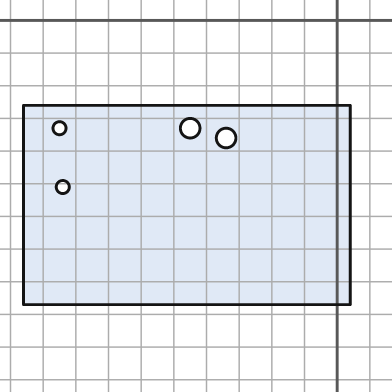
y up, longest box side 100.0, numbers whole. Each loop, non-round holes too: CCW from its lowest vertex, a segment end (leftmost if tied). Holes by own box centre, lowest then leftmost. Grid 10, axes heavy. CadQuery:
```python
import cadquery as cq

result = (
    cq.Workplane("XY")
    .moveTo(-96.0, -87.0)
    .lineTo(4.0, -87.0)
    .lineTo(4.0, -26.0)
    .lineTo(-96.0, -26.0)
    .close()
    .moveTo(-84.0, -51.0)
    .circle(2.0)
    .moveTo(-34.0, -36.0)
    .circle(3.0)
    .moveTo(-85.0, -33.0)
    .circle(2.0)
    .moveTo(-45.0, -33.0)
    .circle(3.0)
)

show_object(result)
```